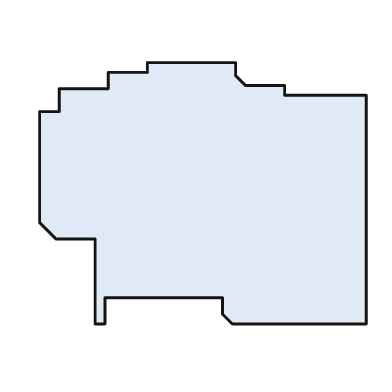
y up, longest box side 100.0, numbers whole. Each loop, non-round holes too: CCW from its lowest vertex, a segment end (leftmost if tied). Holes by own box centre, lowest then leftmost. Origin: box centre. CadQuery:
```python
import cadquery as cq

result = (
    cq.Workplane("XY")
    .moveTo(-33.0, -40.0)
    .lineTo(-30.0, -40.0)
    .lineTo(-30.0, -32.0)
    .lineTo(6.0, -32.0)
    .lineTo(6.0, -37.0)
    .lineTo(9.0, -40.0)
    .lineTo(50.0, -40.0)
    .lineTo(50.0, 30.0)
    .lineTo(25.0, 30.0)
    .lineTo(25.0, 33.0)
    .lineTo(13.0, 33.0)
    .lineTo(10.0, 36.0)
    .lineTo(10.0, 40.0)
    .lineTo(-17.0, 40.0)
    .lineTo(-17.0, 37.0)
    .lineTo(-29.0, 37.0)
    .lineTo(-29.0, 32.0)
    .lineTo(-44.0, 32.0)
    .lineTo(-44.0, 25.0)
    .lineTo(-50.0, 25.0)
    .lineTo(-50.0, -9.0)
    .lineTo(-45.0, -14.0)
    .lineTo(-33.0, -14.0)
    .close()
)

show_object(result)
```